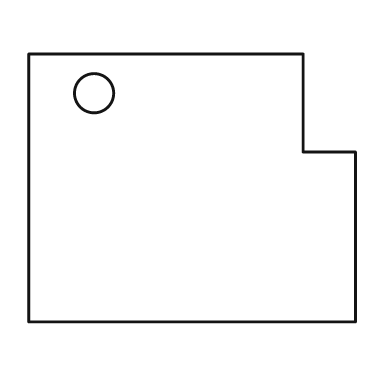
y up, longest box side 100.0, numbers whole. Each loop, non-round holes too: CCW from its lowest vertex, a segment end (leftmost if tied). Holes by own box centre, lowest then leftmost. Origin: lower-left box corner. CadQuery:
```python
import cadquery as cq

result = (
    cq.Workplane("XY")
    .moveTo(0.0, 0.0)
    .lineTo(100.0, 0.0)
    .lineTo(100.0, 52.0)
    .lineTo(84.0, 52.0)
    .lineTo(84.0, 82.0)
    .lineTo(0.0, 82.0)
    .close()
    .moveTo(20.0, 70.0)
    .circle(6.0)
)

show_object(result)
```